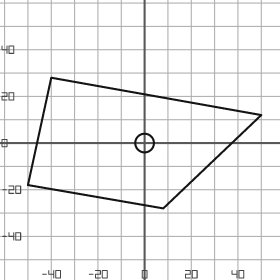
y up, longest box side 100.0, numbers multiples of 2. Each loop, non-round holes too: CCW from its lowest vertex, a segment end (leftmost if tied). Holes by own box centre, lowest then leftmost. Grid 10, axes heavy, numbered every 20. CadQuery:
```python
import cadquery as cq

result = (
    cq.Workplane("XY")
    .moveTo(8.0, -28.0)
    .lineTo(50.0, 12.0)
    .lineTo(-40.0, 28.0)
    .lineTo(-50.0, -18.0)
    .close()
    .moveTo(0.0, 0.0)
    .circle(4.0)
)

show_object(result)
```